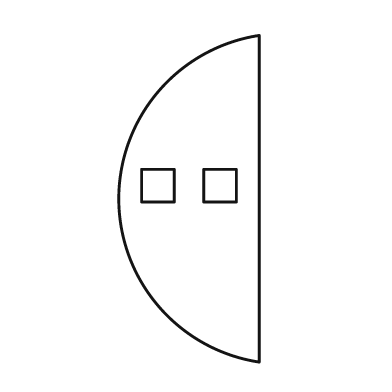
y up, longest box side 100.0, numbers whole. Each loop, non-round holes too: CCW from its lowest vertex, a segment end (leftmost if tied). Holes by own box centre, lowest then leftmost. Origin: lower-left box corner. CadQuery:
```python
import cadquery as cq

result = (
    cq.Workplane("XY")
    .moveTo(43.0, 0.0)
    .lineTo(43.0, 100.0)
    .threePointArc((0.0, 50.0), (43.0, 0.0))
    .close()
    .moveTo(7.0, 49.0)
    .lineTo(17.0, 49.0)
    .lineTo(17.0, 59.0)
    .lineTo(7.0, 59.0)
    .close()
    .moveTo(26.0, 49.0)
    .lineTo(36.0, 49.0)
    .lineTo(36.0, 59.0)
    .lineTo(26.0, 59.0)
    .close()
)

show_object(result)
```